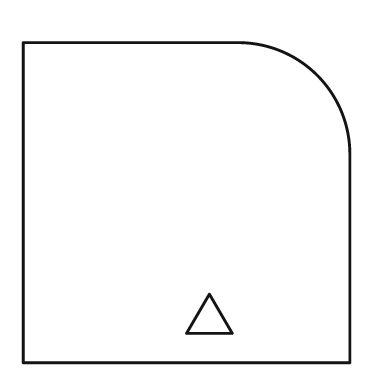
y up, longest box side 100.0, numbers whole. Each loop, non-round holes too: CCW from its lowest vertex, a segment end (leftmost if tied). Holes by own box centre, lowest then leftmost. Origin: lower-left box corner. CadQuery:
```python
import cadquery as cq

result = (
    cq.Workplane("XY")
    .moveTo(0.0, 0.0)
    .lineTo(100.0, 0.0)
    .lineTo(100.0, 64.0)
    .threePointArc((90.0, 88.0), (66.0, 98.0))
    .lineTo(0.0, 98.0)
    .close()
    .moveTo(50.0, 9.0)
    .lineTo(64.0, 9.0)
    .lineTo(57.0, 21.0)
    .close()
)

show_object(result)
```